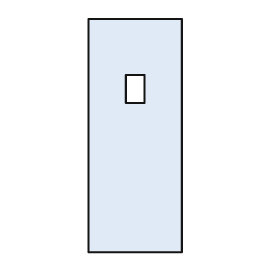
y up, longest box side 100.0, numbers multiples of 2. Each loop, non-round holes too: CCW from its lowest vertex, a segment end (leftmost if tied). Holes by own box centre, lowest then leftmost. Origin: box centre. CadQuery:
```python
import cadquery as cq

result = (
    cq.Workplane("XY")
    .moveTo(-20.0, -50.0)
    .lineTo(20.0, -50.0)
    .lineTo(20.0, 50.0)
    .lineTo(-20.0, 50.0)
    .close()
    .moveTo(-4.0, 14.0)
    .lineTo(4.0, 14.0)
    .lineTo(4.0, 26.0)
    .lineTo(-4.0, 26.0)
    .close()
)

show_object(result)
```